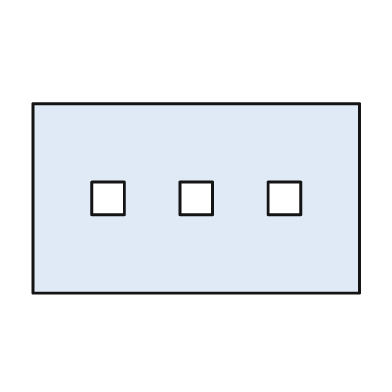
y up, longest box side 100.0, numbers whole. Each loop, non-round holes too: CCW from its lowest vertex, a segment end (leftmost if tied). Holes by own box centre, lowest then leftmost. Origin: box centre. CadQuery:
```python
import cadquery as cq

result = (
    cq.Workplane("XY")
    .moveTo(-50.0, -29.0)
    .lineTo(50.0, -29.0)
    .lineTo(50.0, 29.0)
    .lineTo(-50.0, 29.0)
    .close()
    .moveTo(-32.0, -5.0)
    .lineTo(-22.0, -5.0)
    .lineTo(-22.0, 5.0)
    .lineTo(-32.0, 5.0)
    .close()
    .moveTo(-5.0, -5.0)
    .lineTo(5.0, -5.0)
    .lineTo(5.0, 5.0)
    .lineTo(-5.0, 5.0)
    .close()
    .moveTo(22.0, -5.0)
    .lineTo(32.0, -5.0)
    .lineTo(32.0, 5.0)
    .lineTo(22.0, 5.0)
    .close()
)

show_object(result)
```